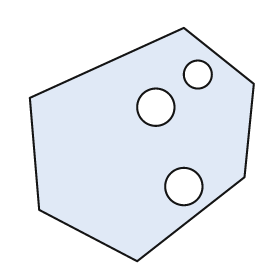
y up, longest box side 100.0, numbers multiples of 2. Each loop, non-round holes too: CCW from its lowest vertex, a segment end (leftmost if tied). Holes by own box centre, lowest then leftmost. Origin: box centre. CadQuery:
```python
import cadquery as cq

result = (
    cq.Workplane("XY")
    .moveTo(-2.0, -50.0)
    .lineTo(44.0, -14.0)
    .lineTo(48.0, 26.0)
    .lineTo(18.0, 50.0)
    .lineTo(-48.0, 20.0)
    .lineTo(-44.0, -28.0)
    .close()
    .moveTo(18.0, -18.0)
    .circle(8.0)
    .moveTo(6.0, 16.0)
    .circle(8.0)
    .moveTo(24.0, 30.0)
    .circle(6.0)
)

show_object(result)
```